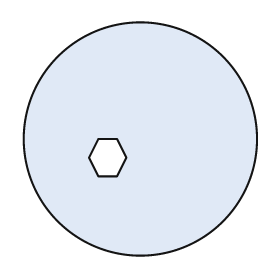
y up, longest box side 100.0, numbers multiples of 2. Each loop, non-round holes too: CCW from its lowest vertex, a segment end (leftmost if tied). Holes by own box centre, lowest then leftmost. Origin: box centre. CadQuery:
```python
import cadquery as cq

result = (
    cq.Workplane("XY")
    .moveTo(0.0, 0.0)
    .circle(50.0)
    .moveTo(-18.0, -16.0)
    .lineTo(-10.0, -16.0)
    .lineTo(-6.0, -8.0)
    .lineTo(-10.0, 0.0)
    .lineTo(-18.0, 0.0)
    .lineTo(-22.0, -8.0)
    .close()
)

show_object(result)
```